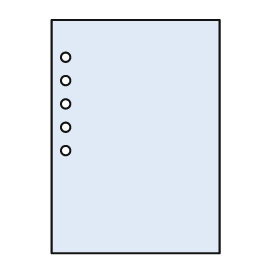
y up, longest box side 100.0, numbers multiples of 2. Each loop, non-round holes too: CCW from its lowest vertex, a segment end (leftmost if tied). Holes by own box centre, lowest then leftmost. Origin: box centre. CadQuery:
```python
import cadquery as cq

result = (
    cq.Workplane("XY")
    .moveTo(-36.0, -50.0)
    .lineTo(36.0, -50.0)
    .lineTo(36.0, 50.0)
    .lineTo(-36.0, 50.0)
    .close()
    .moveTo(-30.0, -6.0)
    .circle(2.0)
    .moveTo(-30.0, 4.0)
    .circle(2.0)
    .moveTo(-30.0, 14.0)
    .circle(2.0)
    .moveTo(-30.0, 24.0)
    .circle(2.0)
    .moveTo(-30.0, 34.0)
    .circle(2.0)
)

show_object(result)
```